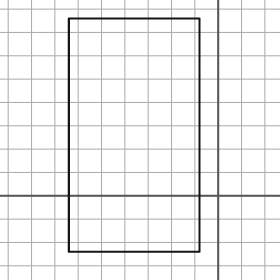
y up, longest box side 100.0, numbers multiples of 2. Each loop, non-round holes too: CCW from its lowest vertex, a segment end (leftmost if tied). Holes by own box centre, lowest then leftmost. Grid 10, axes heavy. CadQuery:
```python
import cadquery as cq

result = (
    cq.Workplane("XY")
    .moveTo(-64.0, -24.0)
    .lineTo(-8.0, -24.0)
    .lineTo(-8.0, 76.0)
    .lineTo(-64.0, 76.0)
    .close()
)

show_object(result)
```